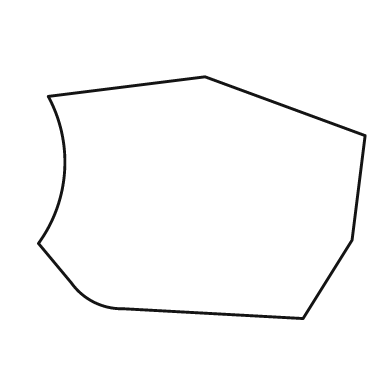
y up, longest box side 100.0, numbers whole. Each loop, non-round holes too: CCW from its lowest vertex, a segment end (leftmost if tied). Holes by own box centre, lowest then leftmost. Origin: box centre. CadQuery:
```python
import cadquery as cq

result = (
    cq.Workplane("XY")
    .moveTo(31.0, -37.0)
    .lineTo(46.0, -13.0)
    .lineTo(50.0, 19.0)
    .lineTo(1.0, 37.0)
    .lineTo(-47.0, 31.0)
    .threePointArc((-42.0, 8.0), (-50.0, -14.0))
    .lineTo(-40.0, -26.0)
    .threePointArc((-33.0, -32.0), (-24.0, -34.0))
    .close()
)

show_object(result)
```